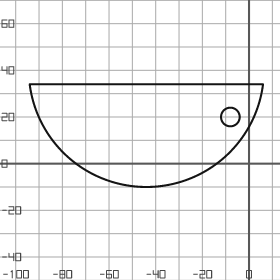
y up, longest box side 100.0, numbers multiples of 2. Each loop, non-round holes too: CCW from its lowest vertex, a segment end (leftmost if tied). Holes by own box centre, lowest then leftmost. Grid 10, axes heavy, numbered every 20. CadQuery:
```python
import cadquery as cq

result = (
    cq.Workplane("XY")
    .moveTo(-94.0, 34.0)
    .threePointArc((-44.0, -10.0), (6.0, 34.0))
    .close()
    .moveTo(-8.0, 20.0)
    .circle(4.0)
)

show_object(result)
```